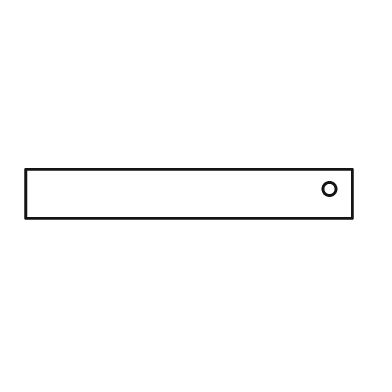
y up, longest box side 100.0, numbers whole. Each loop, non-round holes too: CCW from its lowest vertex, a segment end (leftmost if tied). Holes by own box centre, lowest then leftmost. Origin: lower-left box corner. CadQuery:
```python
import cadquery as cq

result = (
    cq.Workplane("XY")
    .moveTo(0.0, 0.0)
    .lineTo(100.0, 0.0)
    .lineTo(100.0, 15.0)
    .lineTo(0.0, 15.0)
    .close()
    .moveTo(93.0, 9.0)
    .circle(2.0)
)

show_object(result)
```